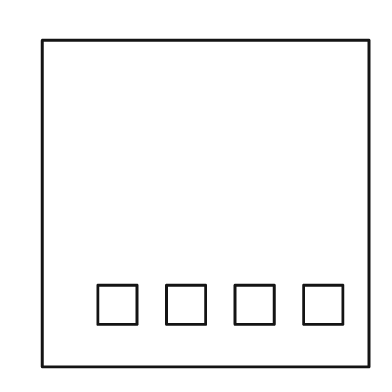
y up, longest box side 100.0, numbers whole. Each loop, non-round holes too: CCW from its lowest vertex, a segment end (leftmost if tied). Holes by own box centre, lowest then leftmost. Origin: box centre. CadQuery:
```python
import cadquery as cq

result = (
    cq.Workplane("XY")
    .moveTo(-50.0, -50.0)
    .lineTo(50.0, -50.0)
    .lineTo(50.0, 50.0)
    .lineTo(-50.0, 50.0)
    .close()
    .moveTo(-33.0, -37.0)
    .lineTo(-21.0, -37.0)
    .lineTo(-21.0, -25.0)
    .lineTo(-33.0, -25.0)
    .close()
    .moveTo(-12.0, -37.0)
    .lineTo(0.0, -37.0)
    .lineTo(0.0, -25.0)
    .lineTo(-12.0, -25.0)
    .close()
    .moveTo(9.0, -37.0)
    .lineTo(21.0, -37.0)
    .lineTo(21.0, -25.0)
    .lineTo(9.0, -25.0)
    .close()
    .moveTo(30.0, -37.0)
    .lineTo(42.0, -37.0)
    .lineTo(42.0, -25.0)
    .lineTo(30.0, -25.0)
    .close()
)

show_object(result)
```